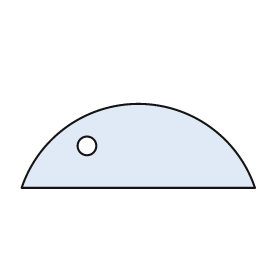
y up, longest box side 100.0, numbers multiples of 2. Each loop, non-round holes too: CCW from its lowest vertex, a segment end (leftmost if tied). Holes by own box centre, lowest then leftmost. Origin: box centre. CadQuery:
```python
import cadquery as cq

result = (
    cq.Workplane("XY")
    .moveTo(-50.0, -18.0)
    .lineTo(50.0, -18.0)
    .threePointArc((0.0, 18.0), (-50.0, -18.0))
    .close()
    .moveTo(-22.0, 0.0)
    .circle(4.0)
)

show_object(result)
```